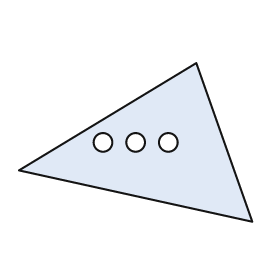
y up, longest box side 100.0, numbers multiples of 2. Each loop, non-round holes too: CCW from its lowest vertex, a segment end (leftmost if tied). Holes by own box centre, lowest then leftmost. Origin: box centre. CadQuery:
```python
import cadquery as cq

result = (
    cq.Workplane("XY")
    .moveTo(50.0, -34.0)
    .lineTo(26.0, 34.0)
    .lineTo(-50.0, -12.0)
    .close()
    .moveTo(-14.0, 0.0)
    .circle(4.0)
    .moveTo(0.0, 0.0)
    .circle(4.0)
    .moveTo(14.0, 0.0)
    .circle(4.0)
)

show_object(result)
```